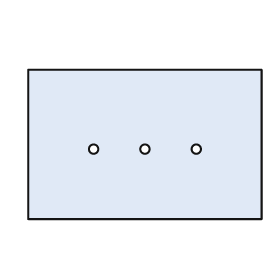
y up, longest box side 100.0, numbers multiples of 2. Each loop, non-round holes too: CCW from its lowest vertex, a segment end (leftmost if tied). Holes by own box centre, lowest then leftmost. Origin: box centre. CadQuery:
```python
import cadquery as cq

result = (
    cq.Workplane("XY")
    .moveTo(-50.0, -32.0)
    .lineTo(50.0, -32.0)
    .lineTo(50.0, 32.0)
    .lineTo(-50.0, 32.0)
    .close()
    .moveTo(-22.0, -2.0)
    .circle(2.0)
    .moveTo(0.0, -2.0)
    .circle(2.0)
    .moveTo(22.0, -2.0)
    .circle(2.0)
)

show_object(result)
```